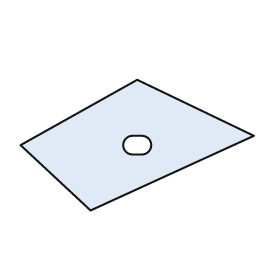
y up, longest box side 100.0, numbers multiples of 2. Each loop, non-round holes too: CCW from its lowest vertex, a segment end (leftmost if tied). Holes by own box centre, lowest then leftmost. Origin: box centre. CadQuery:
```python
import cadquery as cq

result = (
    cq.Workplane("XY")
    .moveTo(-20.0, -28.0)
    .lineTo(50.0, 4.0)
    .lineTo(0.0, 28.0)
    .lineTo(-50.0, 0.0)
    .close()
    .moveTo(-2.0, -4.0)
    .lineTo(2.0, -4.0)
    .threePointArc((6.0, 0.0), (2.0, 4.0))
    .lineTo(-2.0, 4.0)
    .threePointArc((-6.0, 0.0), (-2.0, -4.0))
    .close()
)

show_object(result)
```